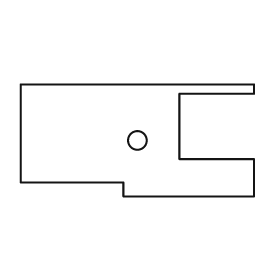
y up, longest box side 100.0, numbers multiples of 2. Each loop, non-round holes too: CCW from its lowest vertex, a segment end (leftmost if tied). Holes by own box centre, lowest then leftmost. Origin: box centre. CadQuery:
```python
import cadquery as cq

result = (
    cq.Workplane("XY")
    .moveTo(-6.0, -24.0)
    .lineTo(50.0, -24.0)
    .lineTo(50.0, -8.0)
    .lineTo(18.0, -8.0)
    .lineTo(18.0, 20.0)
    .lineTo(50.0, 20.0)
    .lineTo(50.0, 24.0)
    .lineTo(-50.0, 24.0)
    .lineTo(-50.0, -18.0)
    .lineTo(-6.0, -18.0)
    .close()
    .moveTo(0.0, 0.0)
    .circle(4.0)
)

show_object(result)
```